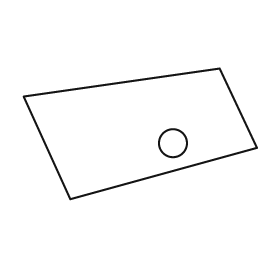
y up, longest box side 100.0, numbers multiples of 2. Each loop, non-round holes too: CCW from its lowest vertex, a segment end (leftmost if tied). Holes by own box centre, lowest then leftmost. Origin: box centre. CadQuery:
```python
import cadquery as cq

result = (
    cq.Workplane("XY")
    .moveTo(-30.0, -28.0)
    .lineTo(50.0, -6.0)
    .lineTo(34.0, 28.0)
    .lineTo(-50.0, 16.0)
    .close()
    .moveTo(14.0, -4.0)
    .circle(6.0)
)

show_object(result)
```